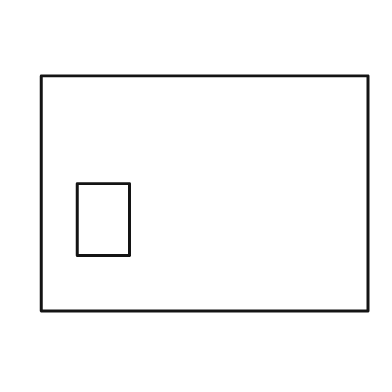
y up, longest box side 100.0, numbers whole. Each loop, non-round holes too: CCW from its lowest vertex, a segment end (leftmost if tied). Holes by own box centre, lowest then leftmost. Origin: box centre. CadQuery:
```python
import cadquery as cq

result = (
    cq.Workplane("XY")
    .moveTo(-50.0, -36.0)
    .lineTo(50.0, -36.0)
    .lineTo(50.0, 36.0)
    .lineTo(-50.0, 36.0)
    .close()
    .moveTo(-39.0, -19.0)
    .lineTo(-23.0, -19.0)
    .lineTo(-23.0, 3.0)
    .lineTo(-39.0, 3.0)
    .close()
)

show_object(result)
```